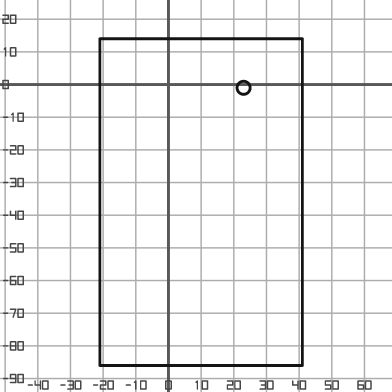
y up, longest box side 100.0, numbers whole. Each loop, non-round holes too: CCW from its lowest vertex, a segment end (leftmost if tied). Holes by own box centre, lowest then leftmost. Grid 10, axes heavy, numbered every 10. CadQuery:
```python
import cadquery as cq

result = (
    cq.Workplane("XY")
    .moveTo(-21.0, -86.0)
    .lineTo(41.0, -86.0)
    .lineTo(41.0, 14.0)
    .lineTo(-21.0, 14.0)
    .close()
    .moveTo(23.0, -1.0)
    .circle(2.0)
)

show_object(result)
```